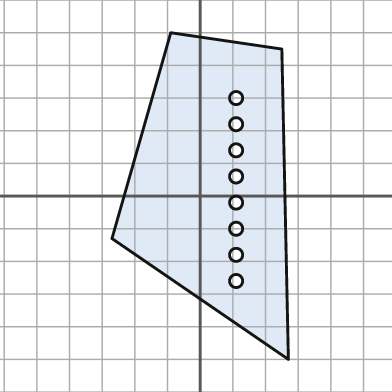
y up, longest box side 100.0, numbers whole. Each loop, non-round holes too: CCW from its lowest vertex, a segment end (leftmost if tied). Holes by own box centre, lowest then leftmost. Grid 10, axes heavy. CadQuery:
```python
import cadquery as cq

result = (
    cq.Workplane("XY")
    .moveTo(27.0, -50.0)
    .lineTo(25.0, 45.0)
    .lineTo(-9.0, 50.0)
    .lineTo(-27.0, -13.0)
    .close()
    .moveTo(11.0, -26.0)
    .circle(2.0)
    .moveTo(11.0, -18.0)
    .circle(2.0)
    .moveTo(11.0, -10.0)
    .circle(2.0)
    .moveTo(11.0, -2.0)
    .circle(2.0)
    .moveTo(11.0, 6.0)
    .circle(2.0)
    .moveTo(11.0, 14.0)
    .circle(2.0)
    .moveTo(11.0, 22.0)
    .circle(2.0)
    .moveTo(11.0, 30.0)
    .circle(2.0)
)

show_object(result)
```